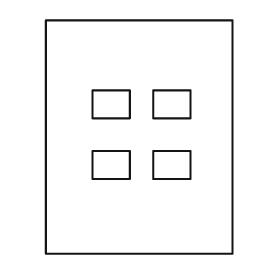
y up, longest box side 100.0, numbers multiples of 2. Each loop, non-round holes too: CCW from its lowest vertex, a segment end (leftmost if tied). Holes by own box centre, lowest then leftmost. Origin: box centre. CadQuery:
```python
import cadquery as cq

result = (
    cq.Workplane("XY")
    .moveTo(-40.0, -50.0)
    .lineTo(40.0, -50.0)
    .lineTo(40.0, 50.0)
    .lineTo(-40.0, 50.0)
    .close()
    .moveTo(-20.0, -18.0)
    .lineTo(-4.0, -18.0)
    .lineTo(-4.0, -6.0)
    .lineTo(-20.0, -6.0)
    .close()
    .moveTo(6.0, -18.0)
    .lineTo(22.0, -18.0)
    .lineTo(22.0, -6.0)
    .lineTo(6.0, -6.0)
    .close()
    .moveTo(-20.0, 8.0)
    .lineTo(-4.0, 8.0)
    .lineTo(-4.0, 20.0)
    .lineTo(-20.0, 20.0)
    .close()
    .moveTo(6.0, 8.0)
    .lineTo(22.0, 8.0)
    .lineTo(22.0, 20.0)
    .lineTo(6.0, 20.0)
    .close()
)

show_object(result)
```